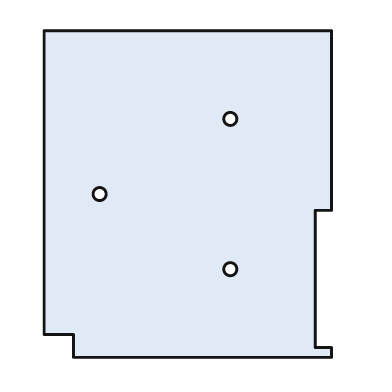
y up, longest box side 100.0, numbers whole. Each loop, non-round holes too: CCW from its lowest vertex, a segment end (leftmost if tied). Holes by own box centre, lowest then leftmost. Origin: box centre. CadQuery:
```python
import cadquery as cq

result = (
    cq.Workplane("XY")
    .moveTo(-35.0, -50.0)
    .lineTo(44.0, -50.0)
    .lineTo(44.0, -47.0)
    .lineTo(39.0, -47.0)
    .lineTo(39.0, -5.0)
    .lineTo(44.0, -5.0)
    .lineTo(44.0, 50.0)
    .lineTo(-44.0, 50.0)
    .lineTo(-44.0, -43.0)
    .lineTo(-35.0, -43.0)
    .close()
    .moveTo(13.0, -23.0)
    .circle(2.0)
    .moveTo(-27.0, 0.0)
    .circle(2.0)
    .moveTo(13.0, 23.0)
    .circle(2.0)
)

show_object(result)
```